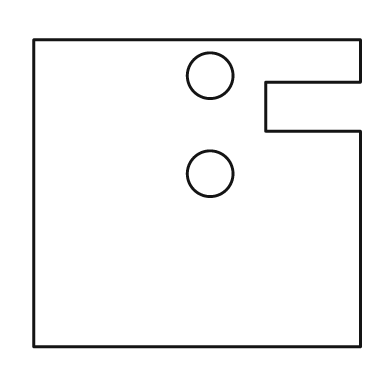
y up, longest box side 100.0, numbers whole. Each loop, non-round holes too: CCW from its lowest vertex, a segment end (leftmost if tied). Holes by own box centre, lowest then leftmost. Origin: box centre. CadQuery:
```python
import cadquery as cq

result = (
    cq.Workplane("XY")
    .moveTo(-50.0, -47.0)
    .lineTo(50.0, -47.0)
    .lineTo(50.0, 19.0)
    .lineTo(21.0, 19.0)
    .lineTo(21.0, 34.0)
    .lineTo(50.0, 34.0)
    .lineTo(50.0, 47.0)
    .lineTo(-50.0, 47.0)
    .close()
    .moveTo(4.0, 6.0)
    .circle(7.0)
    .moveTo(4.0, 36.0)
    .circle(7.0)
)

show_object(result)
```